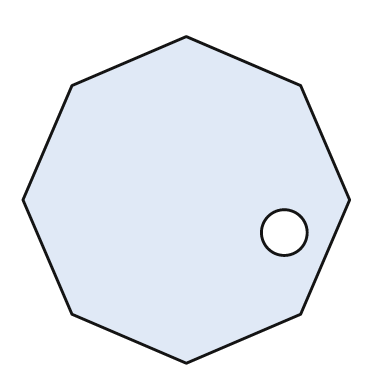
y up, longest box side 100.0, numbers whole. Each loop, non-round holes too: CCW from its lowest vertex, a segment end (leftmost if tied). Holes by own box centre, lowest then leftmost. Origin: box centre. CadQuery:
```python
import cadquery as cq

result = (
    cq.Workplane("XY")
    .moveTo(0.0, -50.0)
    .lineTo(35.0, -35.0)
    .lineTo(50.0, 0.0)
    .lineTo(35.0, 35.0)
    .lineTo(0.0, 50.0)
    .lineTo(-35.0, 35.0)
    .lineTo(-50.0, 0.0)
    .lineTo(-35.0, -35.0)
    .close()
    .moveTo(30.0, -10.0)
    .circle(7.0)
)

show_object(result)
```